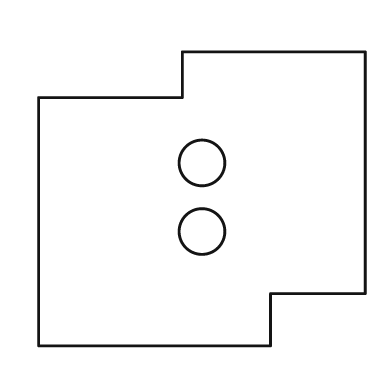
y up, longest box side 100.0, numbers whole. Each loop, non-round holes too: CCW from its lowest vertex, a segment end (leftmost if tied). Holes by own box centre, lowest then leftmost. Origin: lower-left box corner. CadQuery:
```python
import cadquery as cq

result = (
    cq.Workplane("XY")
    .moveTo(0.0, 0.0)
    .lineTo(71.0, 0.0)
    .lineTo(71.0, 16.0)
    .lineTo(100.0, 16.0)
    .lineTo(100.0, 90.0)
    .lineTo(44.0, 90.0)
    .lineTo(44.0, 76.0)
    .lineTo(0.0, 76.0)
    .close()
    .moveTo(50.0, 35.0)
    .circle(7.0)
    .moveTo(50.0, 56.0)
    .circle(7.0)
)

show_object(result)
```